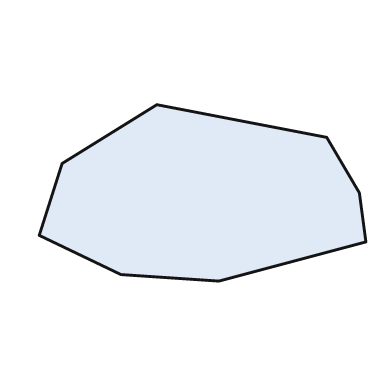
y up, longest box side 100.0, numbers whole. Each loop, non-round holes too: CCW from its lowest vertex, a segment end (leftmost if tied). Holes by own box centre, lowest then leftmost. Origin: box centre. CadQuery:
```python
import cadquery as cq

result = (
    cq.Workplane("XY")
    .moveTo(5.0, -27.0)
    .lineTo(50.0, -15.0)
    .lineTo(48.0, 0.0)
    .lineTo(38.0, 17.0)
    .lineTo(-14.0, 27.0)
    .lineTo(-43.0, 9.0)
    .lineTo(-50.0, -13.0)
    .lineTo(-25.0, -25.0)
    .close()
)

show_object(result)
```